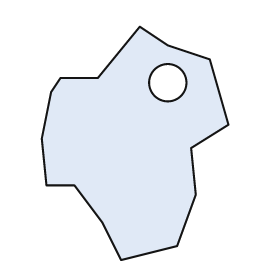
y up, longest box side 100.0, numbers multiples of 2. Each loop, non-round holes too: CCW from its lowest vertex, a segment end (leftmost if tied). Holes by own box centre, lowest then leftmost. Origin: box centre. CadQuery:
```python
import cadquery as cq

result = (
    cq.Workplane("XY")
    .moveTo(-6.0, -50.0)
    .lineTo(18.0, -44.0)
    .lineTo(26.0, -22.0)
    .lineTo(24.0, -2.0)
    .lineTo(40.0, 8.0)
    .lineTo(32.0, 36.0)
    .lineTo(14.0, 42.0)
    .lineTo(2.0, 50.0)
    .lineTo(-16.0, 28.0)
    .lineTo(-32.0, 28.0)
    .lineTo(-36.0, 22.0)
    .lineTo(-40.0, 2.0)
    .lineTo(-38.0, -18.0)
    .lineTo(-26.0, -18.0)
    .lineTo(-14.0, -34.0)
    .close()
    .moveTo(14.0, 26.0)
    .circle(8.0)
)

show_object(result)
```